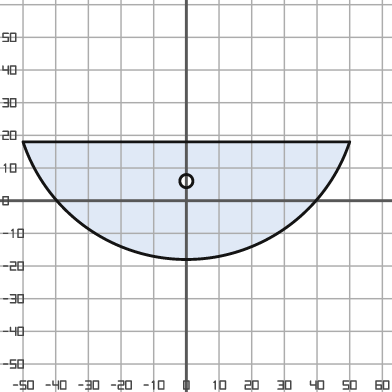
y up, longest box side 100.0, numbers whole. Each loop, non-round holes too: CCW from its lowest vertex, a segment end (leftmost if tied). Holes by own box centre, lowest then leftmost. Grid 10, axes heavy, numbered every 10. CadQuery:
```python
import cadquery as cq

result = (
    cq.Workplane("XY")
    .moveTo(-50.0, 18.0)
    .threePointArc((0.0, -18.0), (50.0, 18.0))
    .close()
    .moveTo(0.0, 6.0)
    .circle(2.0)
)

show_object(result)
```